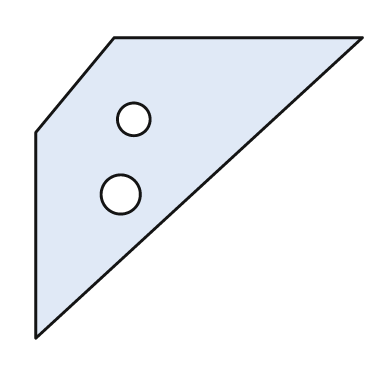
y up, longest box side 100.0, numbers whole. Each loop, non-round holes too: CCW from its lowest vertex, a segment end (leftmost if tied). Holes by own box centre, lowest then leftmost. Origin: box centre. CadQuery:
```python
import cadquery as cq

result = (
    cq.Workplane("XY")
    .moveTo(-50.0, -46.0)
    .lineTo(50.0, 46.0)
    .lineTo(-26.0, 46.0)
    .lineTo(-50.0, 17.0)
    .close()
    .moveTo(-24.0, -2.0)
    .circle(6.0)
    .moveTo(-20.0, 21.0)
    .circle(5.0)
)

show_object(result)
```